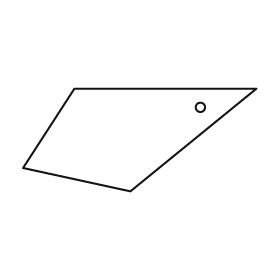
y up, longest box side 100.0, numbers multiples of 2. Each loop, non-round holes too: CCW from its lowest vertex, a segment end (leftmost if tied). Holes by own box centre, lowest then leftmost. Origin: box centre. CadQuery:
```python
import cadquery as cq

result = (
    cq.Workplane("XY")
    .moveTo(-4.0, -22.0)
    .lineTo(50.0, 22.0)
    .lineTo(-28.0, 22.0)
    .lineTo(-50.0, -12.0)
    .close()
    .moveTo(26.0, 14.0)
    .circle(2.0)
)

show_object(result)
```